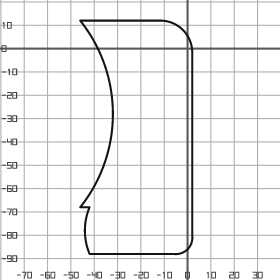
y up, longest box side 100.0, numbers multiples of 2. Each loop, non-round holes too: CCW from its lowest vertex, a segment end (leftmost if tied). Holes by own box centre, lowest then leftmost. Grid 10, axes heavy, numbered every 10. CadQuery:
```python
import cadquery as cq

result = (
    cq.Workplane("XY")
    .moveTo(-42.0, -88.0)
    .lineTo(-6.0, -88.0)
    .threePointArc((0.0, -86.0), (2.0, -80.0))
    .lineTo(2.0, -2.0)
    .threePointArc((-2.0, 8.0), (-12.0, 12.0))
    .lineTo(-46.0, 12.0)
    .threePointArc((-32.0, -28.0), (-46.0, -68.0))
    .lineTo(-42.0, -68.0)
    .threePointArc((-44.0, -78.0), (-42.0, -88.0))
    .close()
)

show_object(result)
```